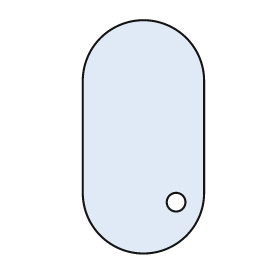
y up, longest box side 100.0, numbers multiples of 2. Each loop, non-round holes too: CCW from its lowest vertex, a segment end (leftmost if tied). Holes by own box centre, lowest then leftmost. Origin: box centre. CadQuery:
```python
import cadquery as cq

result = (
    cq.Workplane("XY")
    .moveTo(-26.0, -24.0)
    .threePointArc((0.0, -50.0), (26.0, -24.0))
    .lineTo(26.0, 24.0)
    .threePointArc((0.0, 50.0), (-26.0, 24.0))
    .close()
    .moveTo(14.0, -28.0)
    .circle(4.0)
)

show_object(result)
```